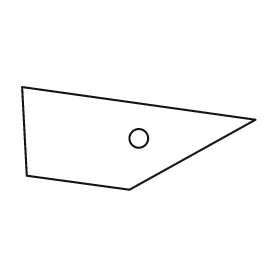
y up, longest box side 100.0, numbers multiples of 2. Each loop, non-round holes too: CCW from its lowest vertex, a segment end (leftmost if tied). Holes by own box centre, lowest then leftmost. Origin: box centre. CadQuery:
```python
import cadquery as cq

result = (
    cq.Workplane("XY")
    .moveTo(-4.0, -22.0)
    .lineTo(50.0, 8.0)
    .lineTo(-50.0, 22.0)
    .lineTo(-48.0, -16.0)
    .close()
    .moveTo(0.0, 0.0)
    .circle(4.0)
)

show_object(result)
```